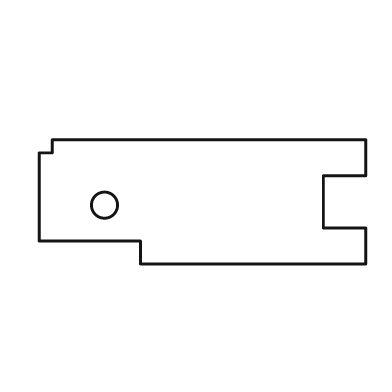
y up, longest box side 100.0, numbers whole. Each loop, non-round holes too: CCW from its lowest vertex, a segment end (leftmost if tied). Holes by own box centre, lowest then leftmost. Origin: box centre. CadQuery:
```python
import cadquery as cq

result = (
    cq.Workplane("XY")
    .moveTo(-19.0, -19.0)
    .lineTo(50.0, -19.0)
    .lineTo(50.0, -8.0)
    .lineTo(37.0, -8.0)
    .lineTo(37.0, 8.0)
    .lineTo(50.0, 8.0)
    .lineTo(50.0, 19.0)
    .lineTo(-46.0, 19.0)
    .lineTo(-46.0, 15.0)
    .lineTo(-50.0, 15.0)
    .lineTo(-50.0, -12.0)
    .lineTo(-19.0, -12.0)
    .close()
    .moveTo(-30.0, -1.0)
    .circle(4.0)
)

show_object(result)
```